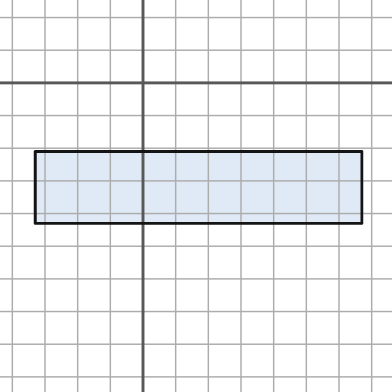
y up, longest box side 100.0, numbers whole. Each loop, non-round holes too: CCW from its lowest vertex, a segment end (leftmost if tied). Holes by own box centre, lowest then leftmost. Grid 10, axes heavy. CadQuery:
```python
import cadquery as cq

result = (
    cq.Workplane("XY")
    .moveTo(-33.0, -43.0)
    .lineTo(67.0, -43.0)
    .lineTo(67.0, -21.0)
    .lineTo(-33.0, -21.0)
    .close()
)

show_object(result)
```